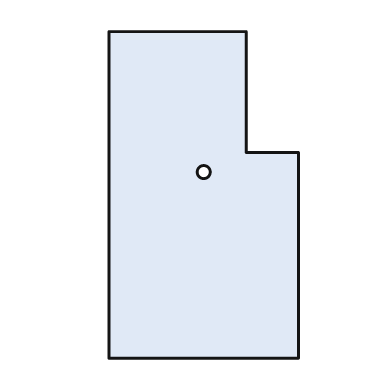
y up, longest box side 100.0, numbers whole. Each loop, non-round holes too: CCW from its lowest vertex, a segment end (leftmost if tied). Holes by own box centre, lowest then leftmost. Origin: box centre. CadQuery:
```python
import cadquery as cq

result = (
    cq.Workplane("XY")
    .moveTo(-29.0, -50.0)
    .lineTo(29.0, -50.0)
    .lineTo(29.0, 13.0)
    .lineTo(13.0, 13.0)
    .lineTo(13.0, 50.0)
    .lineTo(-29.0, 50.0)
    .close()
    .moveTo(0.0, 7.0)
    .circle(2.0)
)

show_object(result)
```